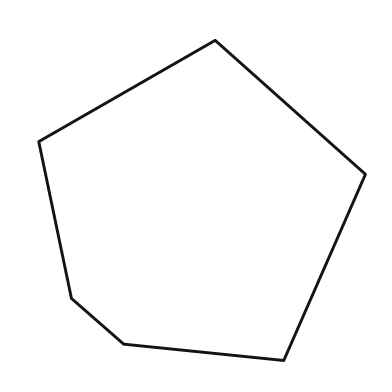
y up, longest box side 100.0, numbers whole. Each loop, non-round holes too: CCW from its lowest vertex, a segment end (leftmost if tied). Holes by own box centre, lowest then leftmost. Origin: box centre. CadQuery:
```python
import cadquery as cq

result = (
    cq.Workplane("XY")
    .moveTo(25.0, -49.0)
    .lineTo(50.0, 8.0)
    .lineTo(4.0, 49.0)
    .lineTo(-50.0, 18.0)
    .lineTo(-40.0, -30.0)
    .lineTo(-24.0, -44.0)
    .close()
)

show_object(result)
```